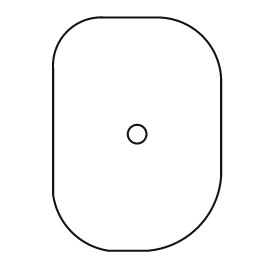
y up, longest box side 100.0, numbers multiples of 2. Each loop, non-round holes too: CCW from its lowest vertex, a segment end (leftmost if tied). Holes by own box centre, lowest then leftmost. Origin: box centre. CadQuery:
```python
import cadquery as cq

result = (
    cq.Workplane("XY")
    .moveTo(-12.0, -50.0)
    .lineTo(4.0, -50.0)
    .threePointArc((26.0, -40.0), (36.0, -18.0))
    .lineTo(36.0, 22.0)
    .threePointArc((28.0, 42.0), (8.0, 50.0))
    .lineTo(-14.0, 50.0)
    .threePointArc((-30.0, 44.0), (-36.0, 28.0))
    .lineTo(-36.0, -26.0)
    .threePointArc((-28.0, -42.0), (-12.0, -50.0))
    .close()
    .moveTo(0.0, 0.0)
    .circle(4.0)
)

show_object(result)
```